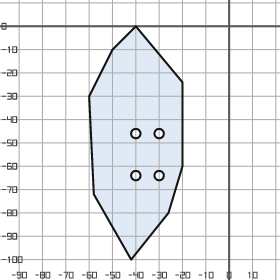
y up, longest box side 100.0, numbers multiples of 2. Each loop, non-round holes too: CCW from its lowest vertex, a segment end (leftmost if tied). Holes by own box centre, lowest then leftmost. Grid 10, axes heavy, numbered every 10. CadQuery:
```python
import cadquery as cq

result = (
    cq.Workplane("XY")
    .moveTo(-42.0, -100.0)
    .lineTo(-26.0, -80.0)
    .lineTo(-20.0, -60.0)
    .lineTo(-20.0, -24.0)
    .lineTo(-40.0, 0.0)
    .lineTo(-50.0, -10.0)
    .lineTo(-60.0, -30.0)
    .lineTo(-58.0, -72.0)
    .close()
    .moveTo(-40.0, -64.0)
    .circle(2.0)
    .moveTo(-30.0, -64.0)
    .circle(2.0)
    .moveTo(-40.0, -46.0)
    .circle(2.0)
    .moveTo(-30.0, -46.0)
    .circle(2.0)
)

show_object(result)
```